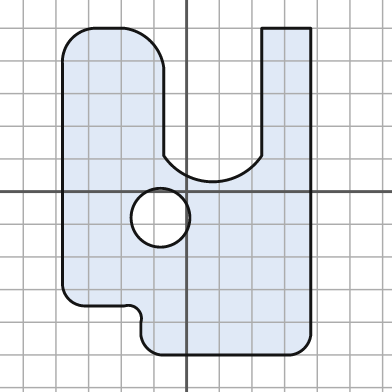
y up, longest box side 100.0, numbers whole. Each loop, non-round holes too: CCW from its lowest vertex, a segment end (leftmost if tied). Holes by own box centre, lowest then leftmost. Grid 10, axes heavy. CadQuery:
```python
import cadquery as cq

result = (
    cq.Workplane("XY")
    .moveTo(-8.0, -50.0)
    .lineTo(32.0, -50.0)
    .threePointArc((36.0, -48.0), (38.0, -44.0))
    .lineTo(38.0, 50.0)
    .lineTo(23.0, 50.0)
    .lineTo(23.0, 11.0)
    .threePointArc((8.0, 3.0), (-7.0, 11.0))
    .lineTo(-7.0, 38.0)
    .threePointArc((-11.0, 46.0), (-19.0, 50.0))
    .lineTo(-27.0, 50.0)
    .threePointArc((-35.0, 47.0), (-38.0, 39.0))
    .lineTo(-38.0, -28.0)
    .threePointArc((-36.0, -33.0), (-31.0, -35.0))
    .lineTo(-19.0, -35.0)
    .threePointArc((-15.0, -36.0), (-14.0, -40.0))
    .lineTo(-14.0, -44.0)
    .threePointArc((-12.0, -48.0), (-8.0, -50.0))
    .close()
    .moveTo(-8.0, -8.0)
    .circle(9.0)
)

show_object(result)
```